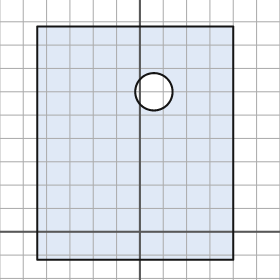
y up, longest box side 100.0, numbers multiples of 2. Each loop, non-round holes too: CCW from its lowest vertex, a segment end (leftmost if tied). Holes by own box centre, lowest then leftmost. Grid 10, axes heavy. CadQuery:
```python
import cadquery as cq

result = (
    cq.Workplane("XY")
    .moveTo(-44.0, -12.0)
    .lineTo(40.0, -12.0)
    .lineTo(40.0, 88.0)
    .lineTo(-44.0, 88.0)
    .close()
    .moveTo(6.0, 60.0)
    .circle(8.0)
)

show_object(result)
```